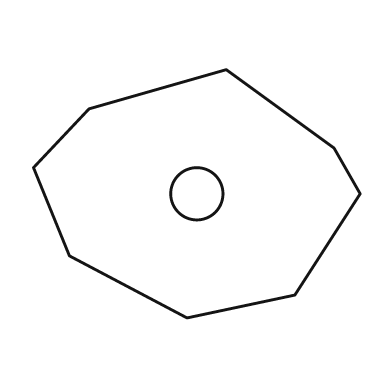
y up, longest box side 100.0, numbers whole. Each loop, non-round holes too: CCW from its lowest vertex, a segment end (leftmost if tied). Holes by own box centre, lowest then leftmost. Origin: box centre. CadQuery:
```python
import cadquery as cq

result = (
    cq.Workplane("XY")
    .moveTo(-3.0, -38.0)
    .lineTo(30.0, -31.0)
    .lineTo(50.0, 0.0)
    .lineTo(42.0, 14.0)
    .lineTo(9.0, 38.0)
    .lineTo(-33.0, 26.0)
    .lineTo(-50.0, 8.0)
    .lineTo(-39.0, -19.0)
    .close()
    .moveTo(0.0, 0.0)
    .circle(8.0)
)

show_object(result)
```